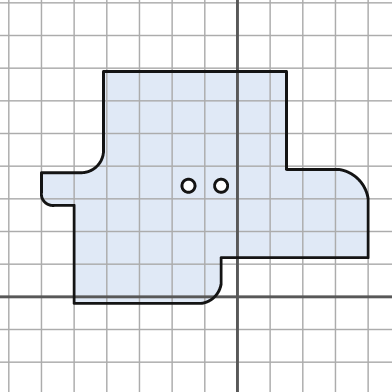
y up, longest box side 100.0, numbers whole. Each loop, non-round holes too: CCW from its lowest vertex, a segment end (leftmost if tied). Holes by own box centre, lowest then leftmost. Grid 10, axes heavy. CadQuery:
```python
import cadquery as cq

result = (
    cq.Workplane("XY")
    .moveTo(-50.0, -2.0)
    .lineTo(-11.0, -2.0)
    .threePointArc((-7.0, 0.0), (-5.0, 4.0))
    .lineTo(-5.0, 12.0)
    .lineTo(40.0, 12.0)
    .lineTo(40.0, 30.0)
    .threePointArc((37.0, 36.0), (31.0, 39.0))
    .lineTo(15.0, 39.0)
    .lineTo(15.0, 69.0)
    .lineTo(-41.0, 69.0)
    .lineTo(-41.0, 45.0)
    .threePointArc((-43.0, 40.0), (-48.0, 38.0))
    .lineTo(-60.0, 38.0)
    .lineTo(-60.0, 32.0)
    .threePointArc((-59.0, 29.0), (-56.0, 28.0))
    .lineTo(-50.0, 28.0)
    .close()
    .moveTo(-15.0, 34.0)
    .circle(2.0)
    .moveTo(-5.0, 34.0)
    .circle(2.0)
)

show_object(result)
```